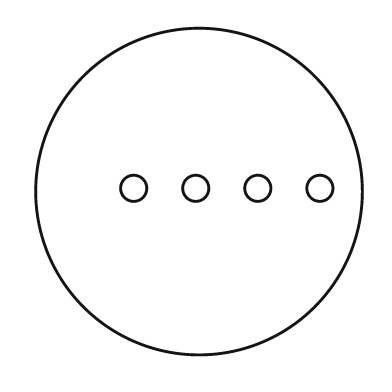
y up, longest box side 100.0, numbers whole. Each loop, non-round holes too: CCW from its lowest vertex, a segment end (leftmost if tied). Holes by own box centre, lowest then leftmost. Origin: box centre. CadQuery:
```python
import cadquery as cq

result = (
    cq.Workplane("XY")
    .moveTo(0.0, 0.0)
    .circle(50.0)
    .moveTo(-20.0, 1.0)
    .circle(4.0)
    .moveTo(-1.0, 1.0)
    .circle(4.0)
    .moveTo(18.0, 1.0)
    .circle(4.0)
    .moveTo(37.0, 1.0)
    .circle(4.0)
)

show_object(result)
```